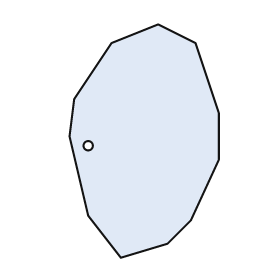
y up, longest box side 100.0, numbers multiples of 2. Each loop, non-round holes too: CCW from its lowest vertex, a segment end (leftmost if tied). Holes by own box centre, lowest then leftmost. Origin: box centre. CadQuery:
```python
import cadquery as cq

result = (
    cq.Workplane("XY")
    .moveTo(-10.0, -50.0)
    .lineTo(10.0, -44.0)
    .lineTo(20.0, -34.0)
    .lineTo(32.0, -8.0)
    .lineTo(32.0, 12.0)
    .lineTo(22.0, 42.0)
    .lineTo(6.0, 50.0)
    .lineTo(-14.0, 42.0)
    .lineTo(-30.0, 18.0)
    .lineTo(-32.0, 2.0)
    .lineTo(-24.0, -32.0)
    .close()
    .moveTo(-24.0, -2.0)
    .circle(2.0)
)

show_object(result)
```